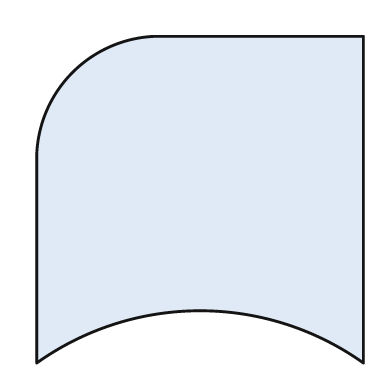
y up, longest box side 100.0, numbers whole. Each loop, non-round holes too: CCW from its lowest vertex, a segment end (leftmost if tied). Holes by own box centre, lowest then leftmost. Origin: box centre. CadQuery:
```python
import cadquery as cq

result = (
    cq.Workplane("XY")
    .moveTo(-50.0, -50.0)
    .threePointArc((0.0, -34.0), (50.0, -50.0))
    .lineTo(50.0, 50.0)
    .lineTo(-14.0, 50.0)
    .threePointArc((-39.0, 39.0), (-50.0, 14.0))
    .close()
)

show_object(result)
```